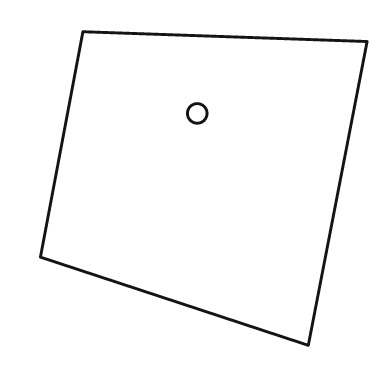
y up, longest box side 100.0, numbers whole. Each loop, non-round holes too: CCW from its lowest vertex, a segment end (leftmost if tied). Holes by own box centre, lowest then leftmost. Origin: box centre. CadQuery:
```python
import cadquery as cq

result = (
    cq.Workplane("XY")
    .moveTo(32.0, -48.0)
    .lineTo(50.0, 45.0)
    .lineTo(-37.0, 48.0)
    .lineTo(-50.0, -21.0)
    .close()
    .moveTo(-2.0, 23.0)
    .circle(3.0)
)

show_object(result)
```